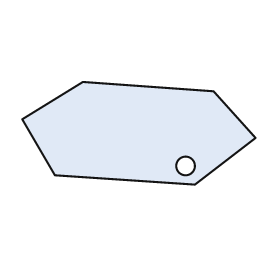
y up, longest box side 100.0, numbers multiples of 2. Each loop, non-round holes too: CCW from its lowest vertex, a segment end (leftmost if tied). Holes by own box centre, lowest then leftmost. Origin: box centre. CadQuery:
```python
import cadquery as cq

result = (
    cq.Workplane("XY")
    .moveTo(24.0, -22.0)
    .lineTo(50.0, -2.0)
    .lineTo(32.0, 18.0)
    .lineTo(-24.0, 22.0)
    .lineTo(-50.0, 6.0)
    .lineTo(-36.0, -18.0)
    .close()
    .moveTo(20.0, -14.0)
    .circle(4.0)
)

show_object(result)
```